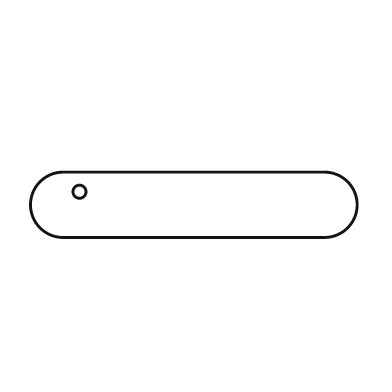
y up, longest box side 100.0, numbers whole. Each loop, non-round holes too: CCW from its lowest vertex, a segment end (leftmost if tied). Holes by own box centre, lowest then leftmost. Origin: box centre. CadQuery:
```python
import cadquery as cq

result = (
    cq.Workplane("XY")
    .moveTo(-40.0, -10.0)
    .lineTo(40.0, -10.0)
    .threePointArc((50.0, 0.0), (40.0, 10.0))
    .lineTo(-40.0, 10.0)
    .threePointArc((-50.0, 0.0), (-40.0, -10.0))
    .close()
    .moveTo(-35.0, 4.0)
    .circle(2.0)
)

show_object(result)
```